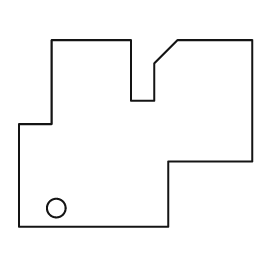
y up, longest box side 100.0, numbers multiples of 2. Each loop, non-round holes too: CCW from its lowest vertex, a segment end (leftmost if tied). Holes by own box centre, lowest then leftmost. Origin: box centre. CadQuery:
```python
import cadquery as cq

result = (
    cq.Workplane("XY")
    .moveTo(-50.0, -40.0)
    .lineTo(14.0, -40.0)
    .lineTo(14.0, -12.0)
    .lineTo(50.0, -12.0)
    .lineTo(50.0, 40.0)
    .lineTo(18.0, 40.0)
    .lineTo(8.0, 30.0)
    .lineTo(8.0, 14.0)
    .lineTo(-2.0, 14.0)
    .lineTo(-2.0, 40.0)
    .lineTo(-36.0, 40.0)
    .lineTo(-36.0, 4.0)
    .lineTo(-50.0, 4.0)
    .close()
    .moveTo(-34.0, -32.0)
    .circle(4.0)
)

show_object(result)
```